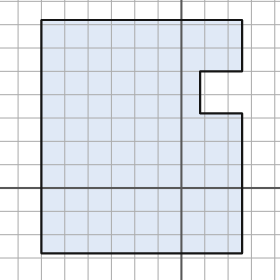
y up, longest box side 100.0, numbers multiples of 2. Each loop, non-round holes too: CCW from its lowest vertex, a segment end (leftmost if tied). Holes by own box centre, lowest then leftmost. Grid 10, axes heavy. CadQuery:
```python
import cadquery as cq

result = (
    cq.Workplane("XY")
    .moveTo(-60.0, -28.0)
    .lineTo(26.0, -28.0)
    .lineTo(26.0, 32.0)
    .lineTo(8.0, 32.0)
    .lineTo(8.0, 50.0)
    .lineTo(26.0, 50.0)
    .lineTo(26.0, 72.0)
    .lineTo(-60.0, 72.0)
    .close()
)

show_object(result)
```